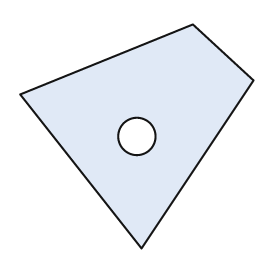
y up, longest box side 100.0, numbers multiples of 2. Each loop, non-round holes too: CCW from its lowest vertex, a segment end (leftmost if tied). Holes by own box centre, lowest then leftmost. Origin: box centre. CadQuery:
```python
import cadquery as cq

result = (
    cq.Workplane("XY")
    .moveTo(2.0, -48.0)
    .lineTo(50.0, 24.0)
    .lineTo(24.0, 48.0)
    .lineTo(-50.0, 18.0)
    .close()
    .moveTo(0.0, 0.0)
    .circle(8.0)
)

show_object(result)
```